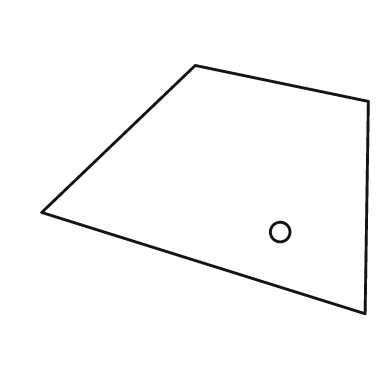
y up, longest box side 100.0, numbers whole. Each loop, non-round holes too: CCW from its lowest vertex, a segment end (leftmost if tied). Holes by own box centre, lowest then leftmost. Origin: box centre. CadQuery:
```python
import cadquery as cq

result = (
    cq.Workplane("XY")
    .moveTo(49.0, -38.0)
    .lineTo(50.0, 27.0)
    .lineTo(-3.0, 38.0)
    .lineTo(-50.0, -7.0)
    .close()
    .moveTo(23.0, -13.0)
    .circle(3.0)
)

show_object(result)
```